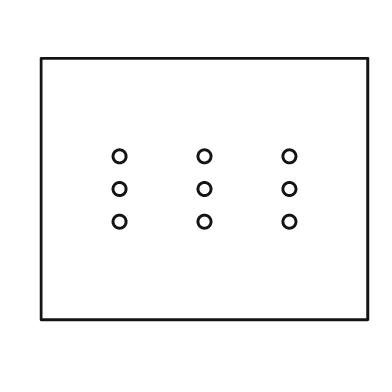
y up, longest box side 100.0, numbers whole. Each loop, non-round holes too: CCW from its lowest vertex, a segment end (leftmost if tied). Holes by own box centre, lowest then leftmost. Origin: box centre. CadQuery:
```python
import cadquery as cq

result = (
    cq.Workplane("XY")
    .moveTo(-50.0, -40.0)
    .lineTo(50.0, -40.0)
    .lineTo(50.0, 40.0)
    .lineTo(-50.0, 40.0)
    .close()
    .moveTo(-26.0, -10.0)
    .circle(2.0)
    .moveTo(0.0, -10.0)
    .circle(2.0)
    .moveTo(26.0, -10.0)
    .circle(2.0)
    .moveTo(-26.0, 0.0)
    .circle(2.0)
    .moveTo(0.0, 0.0)
    .circle(2.0)
    .moveTo(26.0, 0.0)
    .circle(2.0)
    .moveTo(-26.0, 10.0)
    .circle(2.0)
    .moveTo(0.0, 10.0)
    .circle(2.0)
    .moveTo(26.0, 10.0)
    .circle(2.0)
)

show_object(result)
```